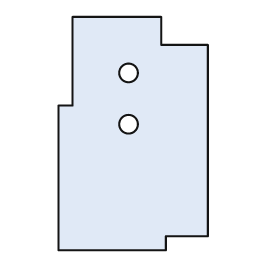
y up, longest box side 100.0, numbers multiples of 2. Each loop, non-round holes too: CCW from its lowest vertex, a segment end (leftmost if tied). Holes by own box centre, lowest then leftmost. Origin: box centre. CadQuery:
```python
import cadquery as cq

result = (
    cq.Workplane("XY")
    .moveTo(-32.0, -50.0)
    .lineTo(14.0, -50.0)
    .lineTo(14.0, -44.0)
    .lineTo(32.0, -44.0)
    .lineTo(32.0, 38.0)
    .lineTo(12.0, 38.0)
    .lineTo(12.0, 50.0)
    .lineTo(-26.0, 50.0)
    .lineTo(-26.0, 12.0)
    .lineTo(-32.0, 12.0)
    .close()
    .moveTo(-2.0, 4.0)
    .circle(4.0)
    .moveTo(-2.0, 26.0)
    .circle(4.0)
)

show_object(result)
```